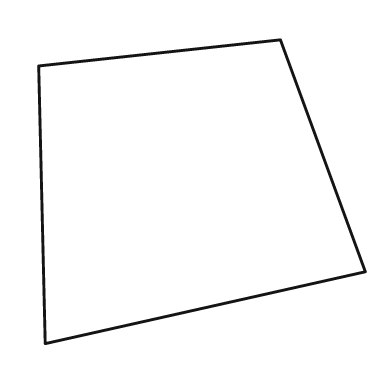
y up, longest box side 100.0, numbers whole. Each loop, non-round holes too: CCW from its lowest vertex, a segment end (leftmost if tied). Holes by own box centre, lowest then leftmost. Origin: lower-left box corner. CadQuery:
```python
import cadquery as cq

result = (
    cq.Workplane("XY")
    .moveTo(2.0, 0.0)
    .lineTo(100.0, 22.0)
    .lineTo(74.0, 93.0)
    .lineTo(0.0, 85.0)
    .close()
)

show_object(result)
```